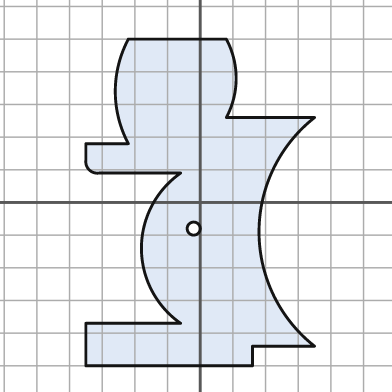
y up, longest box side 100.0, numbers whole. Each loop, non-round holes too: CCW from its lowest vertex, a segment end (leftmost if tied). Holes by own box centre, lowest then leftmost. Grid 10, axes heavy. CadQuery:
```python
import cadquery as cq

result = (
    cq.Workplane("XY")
    .moveTo(-35.0, -50.0)
    .lineTo(16.0, -50.0)
    .lineTo(16.0, -44.0)
    .lineTo(35.0, -44.0)
    .threePointArc((18.0, -9.0), (35.0, 26.0))
    .lineTo(8.0, 26.0)
    .threePointArc((11.0, 38.0), (8.0, 50.0))
    .lineTo(-22.0, 50.0)
    .threePointArc((-26.0, 34.0), (-22.0, 18.0))
    .lineTo(-35.0, 18.0)
    .lineTo(-35.0, 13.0)
    .threePointArc((-34.0, 10.0), (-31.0, 9.0))
    .lineTo(-6.0, 9.0)
    .threePointArc((-18.0, -14.0), (-6.0, -37.0))
    .lineTo(-35.0, -37.0)
    .close()
    .moveTo(-2.0, -8.0)
    .circle(2.0)
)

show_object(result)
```